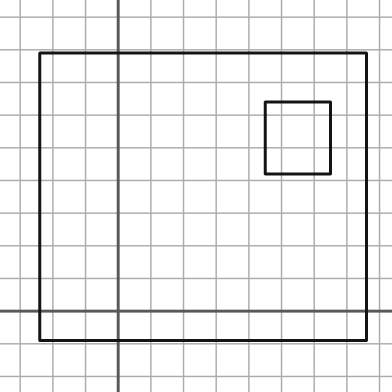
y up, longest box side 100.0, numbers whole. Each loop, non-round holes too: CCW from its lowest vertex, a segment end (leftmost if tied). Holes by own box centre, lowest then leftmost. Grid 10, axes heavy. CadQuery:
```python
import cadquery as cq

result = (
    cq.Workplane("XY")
    .moveTo(-24.0, -9.0)
    .lineTo(76.0, -9.0)
    .lineTo(76.0, 79.0)
    .lineTo(-24.0, 79.0)
    .close()
    .moveTo(45.0, 42.0)
    .lineTo(65.0, 42.0)
    .lineTo(65.0, 64.0)
    .lineTo(45.0, 64.0)
    .close()
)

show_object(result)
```